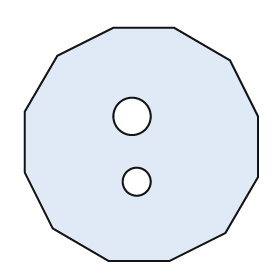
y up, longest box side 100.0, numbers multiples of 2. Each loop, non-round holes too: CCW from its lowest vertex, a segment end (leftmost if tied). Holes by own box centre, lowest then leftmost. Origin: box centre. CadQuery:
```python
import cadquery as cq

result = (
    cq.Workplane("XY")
    .moveTo(-14.0, -50.0)
    .lineTo(12.0, -50.0)
    .lineTo(36.0, -38.0)
    .lineTo(50.0, -14.0)
    .lineTo(50.0, 12.0)
    .lineTo(38.0, 36.0)
    .lineTo(14.0, 50.0)
    .lineTo(-12.0, 50.0)
    .lineTo(-36.0, 38.0)
    .lineTo(-50.0, 14.0)
    .lineTo(-50.0, -12.0)
    .lineTo(-38.0, -36.0)
    .close()
    .moveTo(-2.0, -16.0)
    .circle(6.0)
    .moveTo(-4.0, 12.0)
    .circle(8.0)
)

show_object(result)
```